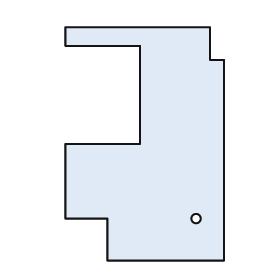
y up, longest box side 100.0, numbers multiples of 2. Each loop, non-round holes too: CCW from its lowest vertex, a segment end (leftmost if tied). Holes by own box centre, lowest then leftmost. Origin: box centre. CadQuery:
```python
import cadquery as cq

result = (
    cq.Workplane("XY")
    .moveTo(-16.0, -50.0)
    .lineTo(34.0, -50.0)
    .lineTo(34.0, 36.0)
    .lineTo(28.0, 36.0)
    .lineTo(28.0, 50.0)
    .lineTo(-34.0, 50.0)
    .lineTo(-34.0, 42.0)
    .lineTo(-2.0, 42.0)
    .lineTo(-2.0, 0.0)
    .lineTo(-34.0, 0.0)
    .lineTo(-34.0, -32.0)
    .lineTo(-16.0, -32.0)
    .close()
    .moveTo(22.0, -32.0)
    .circle(2.0)
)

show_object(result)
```